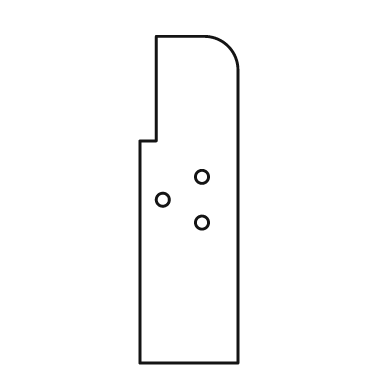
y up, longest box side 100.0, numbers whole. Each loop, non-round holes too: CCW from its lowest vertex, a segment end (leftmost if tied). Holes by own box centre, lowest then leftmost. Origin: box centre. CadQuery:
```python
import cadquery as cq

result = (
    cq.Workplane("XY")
    .moveTo(-15.0, -50.0)
    .lineTo(15.0, -50.0)
    .lineTo(15.0, 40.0)
    .threePointArc((12.0, 47.0), (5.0, 50.0))
    .lineTo(-10.0, 50.0)
    .lineTo(-10.0, 18.0)
    .lineTo(-15.0, 18.0)
    .close()
    .moveTo(4.0, -7.0)
    .circle(2.0)
    .moveTo(-8.0, 0.0)
    .circle(2.0)
    .moveTo(4.0, 7.0)
    .circle(2.0)
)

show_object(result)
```